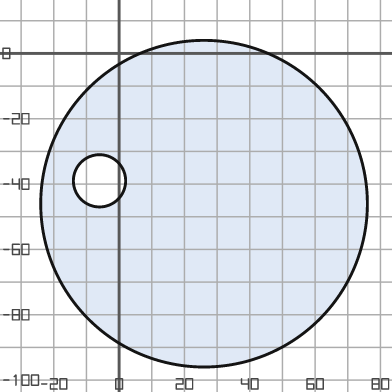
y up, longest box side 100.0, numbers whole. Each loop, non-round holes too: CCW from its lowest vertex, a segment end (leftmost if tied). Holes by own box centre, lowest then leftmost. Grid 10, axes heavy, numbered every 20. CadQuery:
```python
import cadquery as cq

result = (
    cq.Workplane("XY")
    .moveTo(26.0, -46.0)
    .circle(50.0)
    .moveTo(-6.0, -39.0)
    .circle(8.0)
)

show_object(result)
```